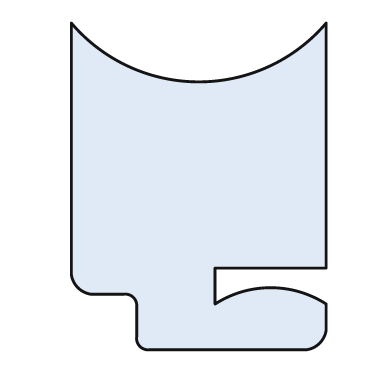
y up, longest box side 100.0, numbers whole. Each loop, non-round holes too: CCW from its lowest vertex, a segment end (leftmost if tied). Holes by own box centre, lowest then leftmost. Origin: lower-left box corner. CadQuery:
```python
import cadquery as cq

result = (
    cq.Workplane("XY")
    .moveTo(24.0, 0.0)
    .lineTo(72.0, 0.0)
    .threePointArc((76.0, 2.0), (78.0, 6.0))
    .lineTo(78.0, 14.0)
    .threePointArc((61.0, 19.0), (44.0, 14.0))
    .lineTo(44.0, 25.0)
    .lineTo(78.0, 25.0)
    .lineTo(78.0, 100.0)
    .threePointArc((39.0, 82.0), (0.0, 100.0))
    .lineTo(0.0, 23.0)
    .threePointArc((2.0, 19.0), (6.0, 17.0))
    .lineTo(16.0, 17.0)
    .threePointArc((19.0, 16.0), (20.0, 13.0))
    .lineTo(20.0, 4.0)
    .threePointArc((21.0, 1.0), (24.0, 0.0))
    .close()
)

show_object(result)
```